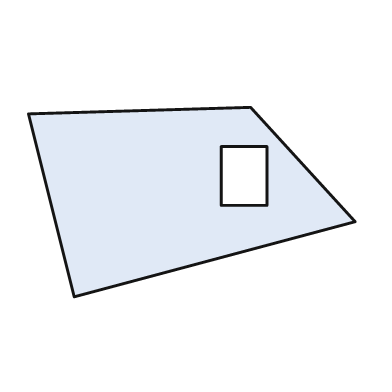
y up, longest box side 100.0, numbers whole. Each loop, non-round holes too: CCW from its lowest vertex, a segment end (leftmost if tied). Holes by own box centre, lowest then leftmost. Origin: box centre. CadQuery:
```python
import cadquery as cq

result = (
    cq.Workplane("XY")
    .moveTo(-36.0, -29.0)
    .lineTo(50.0, -6.0)
    .lineTo(18.0, 29.0)
    .lineTo(-50.0, 27.0)
    .close()
    .moveTo(9.0, -1.0)
    .lineTo(23.0, -1.0)
    .lineTo(23.0, 17.0)
    .lineTo(9.0, 17.0)
    .close()
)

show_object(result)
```